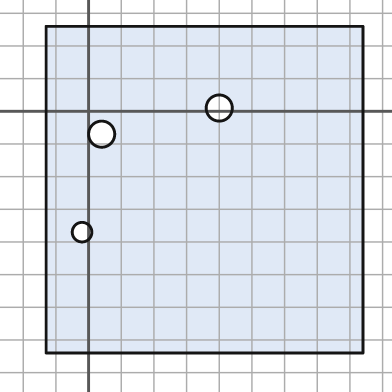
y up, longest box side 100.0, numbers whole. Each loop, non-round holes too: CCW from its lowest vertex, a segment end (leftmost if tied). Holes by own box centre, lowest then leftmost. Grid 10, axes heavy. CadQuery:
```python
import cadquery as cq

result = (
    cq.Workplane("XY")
    .moveTo(-13.0, -74.0)
    .lineTo(84.0, -74.0)
    .lineTo(84.0, 26.0)
    .lineTo(-13.0, 26.0)
    .close()
    .moveTo(-2.0, -37.0)
    .circle(3.0)
    .moveTo(4.0, -7.0)
    .circle(4.0)
    .moveTo(40.0, 1.0)
    .circle(4.0)
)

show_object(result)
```